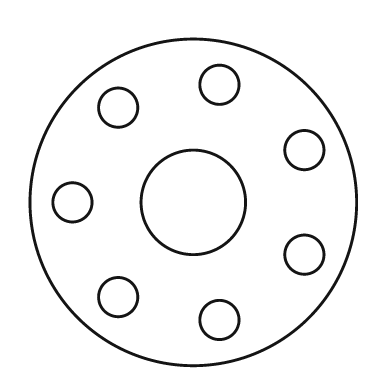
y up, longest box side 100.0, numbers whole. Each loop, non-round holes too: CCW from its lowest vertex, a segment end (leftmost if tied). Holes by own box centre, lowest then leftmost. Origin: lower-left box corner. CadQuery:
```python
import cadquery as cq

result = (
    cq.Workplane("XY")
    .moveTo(50.0, 50.0)
    .circle(50.0)
    .moveTo(58.0, 14.0)
    .circle(6.0)
    .moveTo(27.0, 21.0)
    .circle(6.0)
    .moveTo(84.0, 34.0)
    .circle(6.0)
    .moveTo(13.0, 50.0)
    .circle(6.0)
    .moveTo(50.0, 50.0)
    .circle(16.0)
    .moveTo(84.0, 66.0)
    .circle(6.0)
    .moveTo(27.0, 79.0)
    .circle(6.0)
    .moveTo(58.0, 86.0)
    .circle(6.0)
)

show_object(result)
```